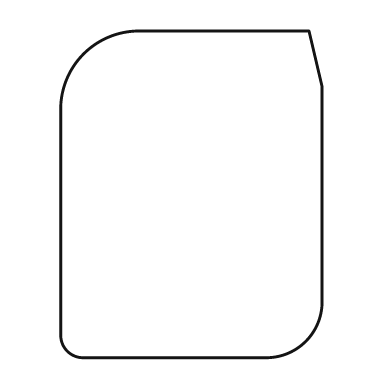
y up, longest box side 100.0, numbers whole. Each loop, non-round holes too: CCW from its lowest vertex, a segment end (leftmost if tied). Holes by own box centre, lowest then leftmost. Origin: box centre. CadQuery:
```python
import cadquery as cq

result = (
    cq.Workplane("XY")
    .moveTo(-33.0, -50.0)
    .lineTo(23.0, -50.0)
    .threePointArc((35.0, -45.0), (40.0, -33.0))
    .lineTo(40.0, 33.0)
    .lineTo(36.0, 50.0)
    .lineTo(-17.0, 50.0)
    .threePointArc((-33.0, 43.0), (-40.0, 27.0))
    .lineTo(-40.0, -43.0)
    .threePointArc((-38.0, -48.0), (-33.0, -50.0))
    .close()
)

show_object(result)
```